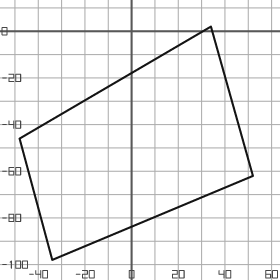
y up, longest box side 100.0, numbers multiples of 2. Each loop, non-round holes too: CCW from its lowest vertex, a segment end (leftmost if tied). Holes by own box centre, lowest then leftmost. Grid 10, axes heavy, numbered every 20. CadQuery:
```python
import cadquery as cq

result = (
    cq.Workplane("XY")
    .moveTo(-34.0, -98.0)
    .lineTo(52.0, -62.0)
    .lineTo(34.0, 2.0)
    .lineTo(-48.0, -46.0)
    .close()
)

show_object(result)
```